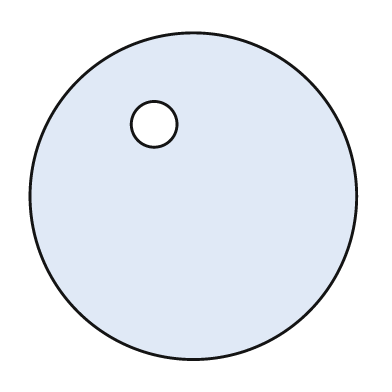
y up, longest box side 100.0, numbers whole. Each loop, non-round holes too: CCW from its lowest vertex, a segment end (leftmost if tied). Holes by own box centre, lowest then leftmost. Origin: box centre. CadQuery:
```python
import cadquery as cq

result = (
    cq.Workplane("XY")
    .moveTo(0.0, 0.0)
    .circle(50.0)
    .moveTo(-12.0, 22.0)
    .circle(7.0)
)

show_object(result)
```